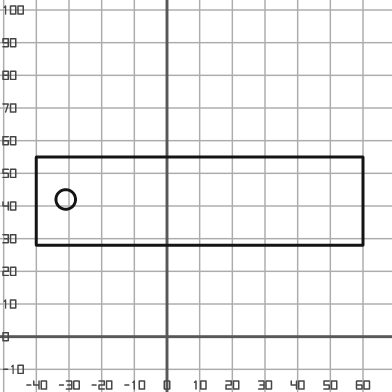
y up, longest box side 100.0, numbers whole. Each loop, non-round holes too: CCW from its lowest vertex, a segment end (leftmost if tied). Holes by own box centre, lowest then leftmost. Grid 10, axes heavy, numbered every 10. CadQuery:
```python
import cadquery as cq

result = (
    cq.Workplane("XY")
    .moveTo(-40.0, 28.0)
    .lineTo(60.0, 28.0)
    .lineTo(60.0, 55.0)
    .lineTo(-40.0, 55.0)
    .close()
    .moveTo(-31.0, 42.0)
    .circle(3.0)
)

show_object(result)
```